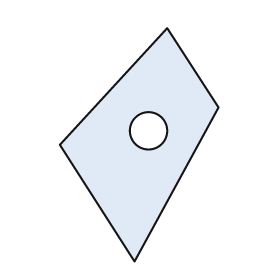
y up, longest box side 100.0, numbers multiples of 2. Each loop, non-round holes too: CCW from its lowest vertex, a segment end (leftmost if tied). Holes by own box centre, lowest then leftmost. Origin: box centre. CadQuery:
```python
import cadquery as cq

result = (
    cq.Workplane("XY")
    .moveTo(-2.0, -50.0)
    .lineTo(34.0, 16.0)
    .lineTo(12.0, 50.0)
    .lineTo(-34.0, 0.0)
    .close()
    .moveTo(4.0, 6.0)
    .circle(8.0)
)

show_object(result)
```